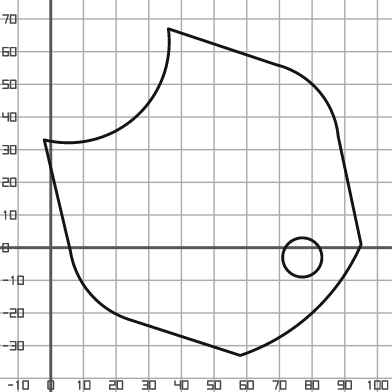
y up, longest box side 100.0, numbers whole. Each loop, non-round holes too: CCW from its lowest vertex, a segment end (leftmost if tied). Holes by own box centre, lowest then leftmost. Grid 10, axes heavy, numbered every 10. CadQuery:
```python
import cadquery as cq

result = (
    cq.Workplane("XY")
    .moveTo(58.0, -33.0)
    .threePointArc((80.0, -20.0), (95.0, 1.0))
    .lineTo(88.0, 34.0)
    .threePointArc((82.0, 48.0), (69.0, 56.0))
    .lineTo(36.0, 67.0)
    .threePointArc((26.0, 40.0), (-2.0, 33.0))
    .lineTo(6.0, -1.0)
    .threePointArc((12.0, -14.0), (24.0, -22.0))
    .close()
    .moveTo(77.0, -3.0)
    .circle(6.0)
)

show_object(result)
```